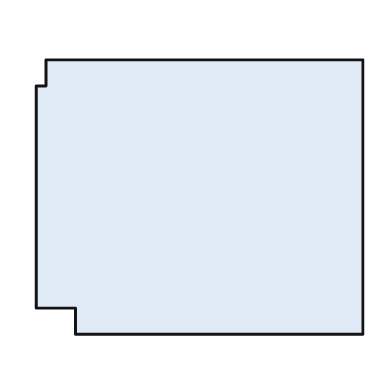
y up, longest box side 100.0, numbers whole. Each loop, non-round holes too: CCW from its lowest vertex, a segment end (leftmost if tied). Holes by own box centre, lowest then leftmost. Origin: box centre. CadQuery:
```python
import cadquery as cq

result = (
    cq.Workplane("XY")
    .moveTo(-38.0, -42.0)
    .lineTo(50.0, -42.0)
    .lineTo(50.0, 42.0)
    .lineTo(-47.0, 42.0)
    .lineTo(-47.0, 34.0)
    .lineTo(-50.0, 34.0)
    .lineTo(-50.0, -34.0)
    .lineTo(-38.0, -34.0)
    .close()
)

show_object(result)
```